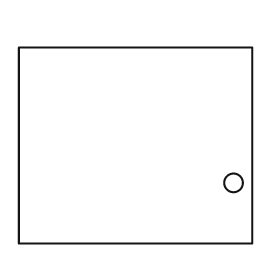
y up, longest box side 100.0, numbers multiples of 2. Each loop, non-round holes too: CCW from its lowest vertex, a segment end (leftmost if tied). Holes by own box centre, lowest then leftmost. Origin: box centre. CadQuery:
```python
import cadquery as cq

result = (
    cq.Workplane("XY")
    .moveTo(-50.0, -42.0)
    .lineTo(50.0, -42.0)
    .lineTo(50.0, 42.0)
    .lineTo(-50.0, 42.0)
    .close()
    .moveTo(42.0, -16.0)
    .circle(4.0)
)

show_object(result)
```